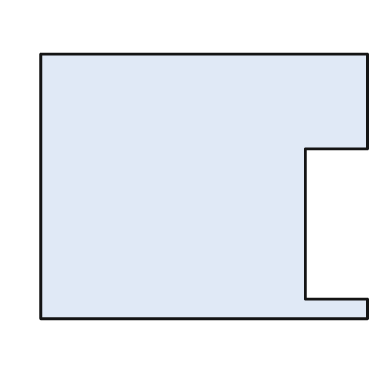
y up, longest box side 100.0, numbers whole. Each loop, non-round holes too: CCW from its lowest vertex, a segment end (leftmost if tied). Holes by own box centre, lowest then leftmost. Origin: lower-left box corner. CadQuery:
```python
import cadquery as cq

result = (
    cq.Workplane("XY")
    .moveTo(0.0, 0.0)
    .lineTo(100.0, 0.0)
    .lineTo(100.0, 6.0)
    .lineTo(81.0, 6.0)
    .lineTo(81.0, 52.0)
    .lineTo(100.0, 52.0)
    .lineTo(100.0, 81.0)
    .lineTo(0.0, 81.0)
    .close()
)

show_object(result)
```